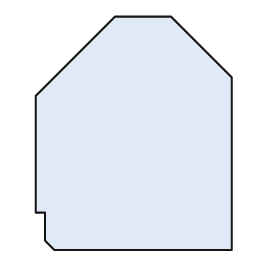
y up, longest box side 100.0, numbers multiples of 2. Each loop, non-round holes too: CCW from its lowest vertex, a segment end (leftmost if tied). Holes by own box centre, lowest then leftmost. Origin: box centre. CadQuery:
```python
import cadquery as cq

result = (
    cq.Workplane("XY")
    .moveTo(-34.0, -50.0)
    .lineTo(42.0, -50.0)
    .lineTo(42.0, 24.0)
    .lineTo(16.0, 50.0)
    .lineTo(-8.0, 50.0)
    .lineTo(-42.0, 16.0)
    .lineTo(-42.0, -34.0)
    .lineTo(-38.0, -34.0)
    .lineTo(-38.0, -46.0)
    .close()
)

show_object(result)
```